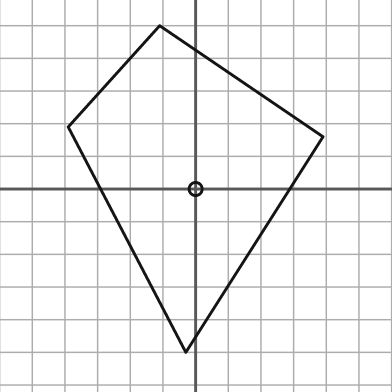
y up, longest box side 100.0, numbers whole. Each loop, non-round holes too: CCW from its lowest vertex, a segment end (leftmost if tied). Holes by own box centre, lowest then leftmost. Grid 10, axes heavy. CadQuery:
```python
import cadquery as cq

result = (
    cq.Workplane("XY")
    .moveTo(-3.0, -50.0)
    .lineTo(39.0, 16.0)
    .lineTo(-11.0, 50.0)
    .lineTo(-39.0, 19.0)
    .close()
    .moveTo(0.0, 0.0)
    .circle(2.0)
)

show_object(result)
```